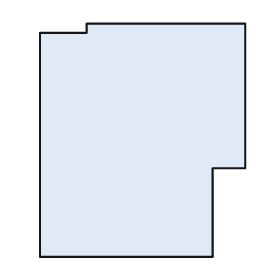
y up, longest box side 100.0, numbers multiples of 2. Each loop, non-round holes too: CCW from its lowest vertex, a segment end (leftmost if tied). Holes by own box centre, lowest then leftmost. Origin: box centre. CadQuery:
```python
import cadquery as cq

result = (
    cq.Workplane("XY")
    .moveTo(-44.0, -50.0)
    .lineTo(30.0, -50.0)
    .lineTo(30.0, -12.0)
    .lineTo(44.0, -12.0)
    .lineTo(44.0, 50.0)
    .lineTo(-24.0, 50.0)
    .lineTo(-24.0, 46.0)
    .lineTo(-44.0, 46.0)
    .close()
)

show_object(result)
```